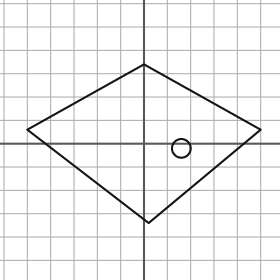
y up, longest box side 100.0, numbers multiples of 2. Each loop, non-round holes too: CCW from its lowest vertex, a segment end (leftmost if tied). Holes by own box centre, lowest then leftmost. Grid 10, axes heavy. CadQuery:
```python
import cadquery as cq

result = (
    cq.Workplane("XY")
    .moveTo(2.0, -34.0)
    .lineTo(50.0, 6.0)
    .lineTo(0.0, 34.0)
    .lineTo(-50.0, 6.0)
    .close()
    .moveTo(16.0, -2.0)
    .circle(4.0)
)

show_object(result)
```